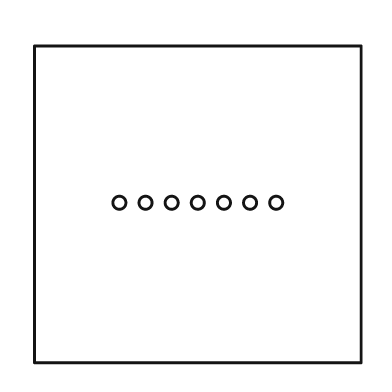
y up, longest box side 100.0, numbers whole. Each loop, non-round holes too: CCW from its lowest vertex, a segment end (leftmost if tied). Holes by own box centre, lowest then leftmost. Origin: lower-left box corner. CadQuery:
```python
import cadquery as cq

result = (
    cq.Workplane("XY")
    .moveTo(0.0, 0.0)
    .lineTo(100.0, 0.0)
    .lineTo(100.0, 97.0)
    .lineTo(0.0, 97.0)
    .close()
    .moveTo(26.0, 49.0)
    .circle(2.0)
    .moveTo(34.0, 49.0)
    .circle(2.0)
    .moveTo(42.0, 49.0)
    .circle(2.0)
    .moveTo(50.0, 49.0)
    .circle(2.0)
    .moveTo(58.0, 49.0)
    .circle(2.0)
    .moveTo(66.0, 49.0)
    .circle(2.0)
    .moveTo(74.0, 49.0)
    .circle(2.0)
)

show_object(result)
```